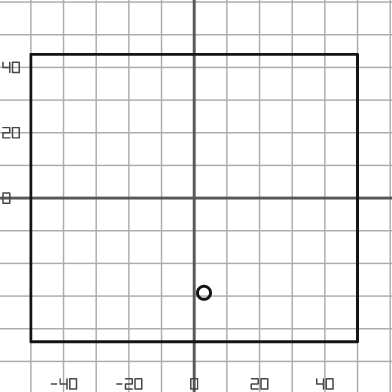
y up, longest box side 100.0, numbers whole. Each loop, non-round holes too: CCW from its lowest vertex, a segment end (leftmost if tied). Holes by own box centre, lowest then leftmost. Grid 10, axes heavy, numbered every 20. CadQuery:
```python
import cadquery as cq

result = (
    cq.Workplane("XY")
    .moveTo(-50.0, -44.0)
    .lineTo(50.0, -44.0)
    .lineTo(50.0, 44.0)
    .lineTo(-50.0, 44.0)
    .close()
    .moveTo(3.0, -29.0)
    .circle(2.0)
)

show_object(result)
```